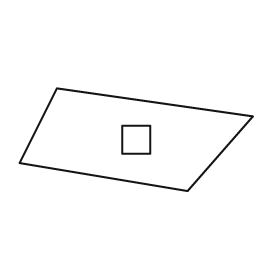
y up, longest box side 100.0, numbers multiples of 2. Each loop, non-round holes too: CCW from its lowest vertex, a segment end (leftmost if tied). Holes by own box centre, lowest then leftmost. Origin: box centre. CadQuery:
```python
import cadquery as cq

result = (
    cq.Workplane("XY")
    .moveTo(22.0, -22.0)
    .lineTo(50.0, 10.0)
    .lineTo(-34.0, 22.0)
    .lineTo(-50.0, -10.0)
    .close()
    .moveTo(-6.0, -6.0)
    .lineTo(6.0, -6.0)
    .lineTo(6.0, 6.0)
    .lineTo(-6.0, 6.0)
    .close()
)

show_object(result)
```